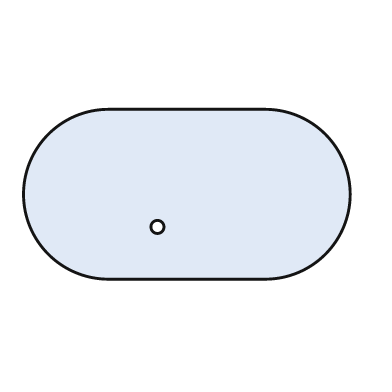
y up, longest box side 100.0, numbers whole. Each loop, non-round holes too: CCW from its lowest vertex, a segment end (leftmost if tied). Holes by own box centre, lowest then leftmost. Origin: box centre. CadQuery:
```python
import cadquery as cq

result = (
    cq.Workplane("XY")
    .moveTo(-24.0, -26.0)
    .lineTo(24.0, -26.0)
    .threePointArc((50.0, 0.0), (24.0, 26.0))
    .lineTo(-24.0, 26.0)
    .threePointArc((-50.0, 0.0), (-24.0, -26.0))
    .close()
    .moveTo(-9.0, -10.0)
    .circle(2.0)
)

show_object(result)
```